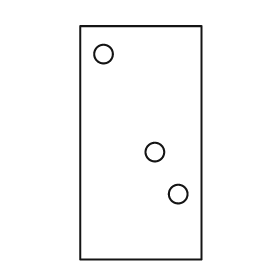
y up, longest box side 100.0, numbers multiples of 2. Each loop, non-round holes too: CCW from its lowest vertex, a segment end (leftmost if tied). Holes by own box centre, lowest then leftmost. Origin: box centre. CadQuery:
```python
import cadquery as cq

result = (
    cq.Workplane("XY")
    .moveTo(-26.0, -50.0)
    .lineTo(26.0, -50.0)
    .lineTo(26.0, 50.0)
    .lineTo(-26.0, 50.0)
    .close()
    .moveTo(16.0, -22.0)
    .circle(4.0)
    .moveTo(6.0, -4.0)
    .circle(4.0)
    .moveTo(-16.0, 38.0)
    .circle(4.0)
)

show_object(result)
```